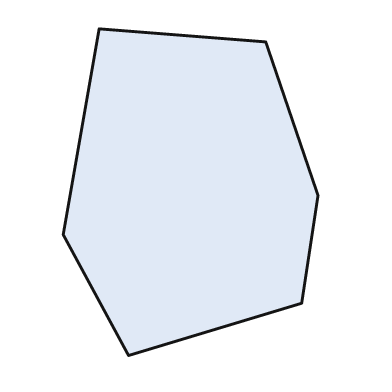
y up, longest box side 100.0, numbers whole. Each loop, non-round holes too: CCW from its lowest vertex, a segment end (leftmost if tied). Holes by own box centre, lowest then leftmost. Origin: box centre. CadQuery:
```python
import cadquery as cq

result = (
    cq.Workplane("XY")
    .moveTo(-19.0, -50.0)
    .lineTo(34.0, -34.0)
    .lineTo(39.0, -1.0)
    .lineTo(23.0, 46.0)
    .lineTo(-28.0, 50.0)
    .lineTo(-39.0, -13.0)
    .close()
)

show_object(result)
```